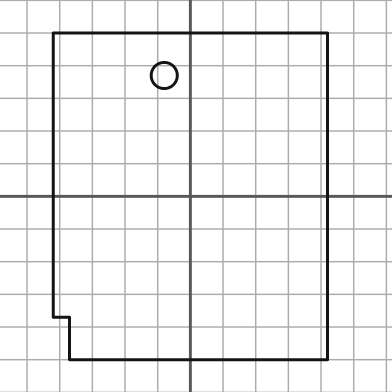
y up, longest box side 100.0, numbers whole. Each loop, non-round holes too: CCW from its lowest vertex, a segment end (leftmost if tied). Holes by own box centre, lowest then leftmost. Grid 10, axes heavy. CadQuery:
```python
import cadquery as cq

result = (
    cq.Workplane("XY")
    .moveTo(-37.0, -50.0)
    .lineTo(42.0, -50.0)
    .lineTo(42.0, 50.0)
    .lineTo(-42.0, 50.0)
    .lineTo(-42.0, -37.0)
    .lineTo(-37.0, -37.0)
    .close()
    .moveTo(-8.0, 37.0)
    .circle(4.0)
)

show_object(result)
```